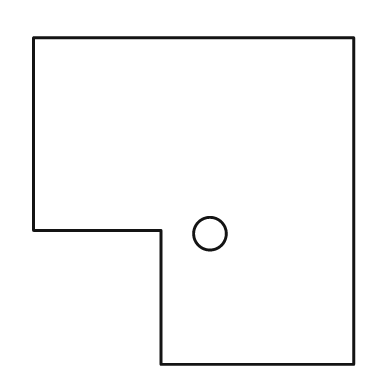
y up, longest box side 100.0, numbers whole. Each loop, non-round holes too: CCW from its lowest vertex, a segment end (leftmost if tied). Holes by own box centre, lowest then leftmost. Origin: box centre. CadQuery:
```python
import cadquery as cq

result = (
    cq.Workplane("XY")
    .moveTo(-10.0, -50.0)
    .lineTo(49.0, -50.0)
    .lineTo(49.0, 50.0)
    .lineTo(-49.0, 50.0)
    .lineTo(-49.0, -9.0)
    .lineTo(-10.0, -9.0)
    .close()
    .moveTo(5.0, -10.0)
    .circle(5.0)
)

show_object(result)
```